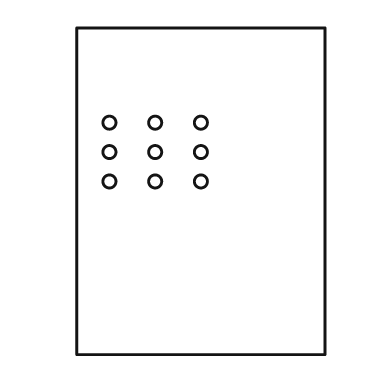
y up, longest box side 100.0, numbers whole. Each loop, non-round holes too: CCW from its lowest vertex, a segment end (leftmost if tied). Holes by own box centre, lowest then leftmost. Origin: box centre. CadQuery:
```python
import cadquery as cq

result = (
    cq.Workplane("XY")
    .moveTo(-38.0, -50.0)
    .lineTo(38.0, -50.0)
    .lineTo(38.0, 50.0)
    .lineTo(-38.0, 50.0)
    .close()
    .moveTo(-28.0, 3.0)
    .circle(2.0)
    .moveTo(-14.0, 3.0)
    .circle(2.0)
    .moveTo(0.0, 3.0)
    .circle(2.0)
    .moveTo(-28.0, 12.0)
    .circle(2.0)
    .moveTo(-14.0, 12.0)
    .circle(2.0)
    .moveTo(0.0, 12.0)
    .circle(2.0)
    .moveTo(-28.0, 21.0)
    .circle(2.0)
    .moveTo(-14.0, 21.0)
    .circle(2.0)
    .moveTo(0.0, 21.0)
    .circle(2.0)
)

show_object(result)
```